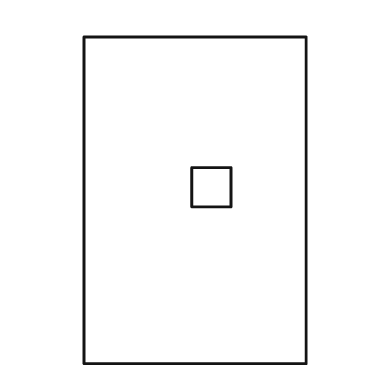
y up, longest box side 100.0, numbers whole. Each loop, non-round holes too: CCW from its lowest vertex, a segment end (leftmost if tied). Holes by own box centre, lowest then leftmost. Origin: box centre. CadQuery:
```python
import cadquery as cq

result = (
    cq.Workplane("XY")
    .moveTo(-34.0, -50.0)
    .lineTo(34.0, -50.0)
    .lineTo(34.0, 50.0)
    .lineTo(-34.0, 50.0)
    .close()
    .moveTo(-1.0, -2.0)
    .lineTo(11.0, -2.0)
    .lineTo(11.0, 10.0)
    .lineTo(-1.0, 10.0)
    .close()
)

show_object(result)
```